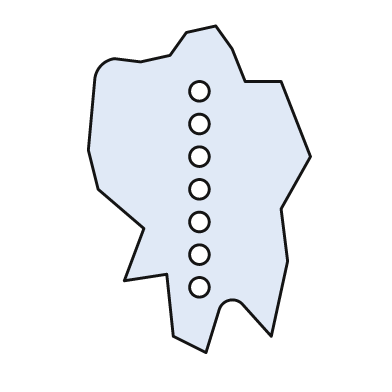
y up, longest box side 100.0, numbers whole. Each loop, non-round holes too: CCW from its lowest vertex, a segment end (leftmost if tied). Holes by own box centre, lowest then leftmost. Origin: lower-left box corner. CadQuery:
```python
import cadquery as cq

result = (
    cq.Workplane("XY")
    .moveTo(36.0, 0.0)
    .lineTo(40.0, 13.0)
    .threePointArc((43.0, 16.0), (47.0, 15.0))
    .lineTo(56.0, 5.0)
    .lineTo(61.0, 28.0)
    .lineTo(59.0, 44.0)
    .lineTo(68.0, 60.0)
    .lineTo(59.0, 83.0)
    .lineTo(48.0, 83.0)
    .lineTo(44.0, 93.0)
    .lineTo(39.0, 100.0)
    .lineTo(30.0, 98.0)
    .lineTo(25.0, 91.0)
    .lineTo(16.0, 89.0)
    .lineTo(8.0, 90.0)
    .threePointArc((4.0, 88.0), (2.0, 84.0))
    .lineTo(0.0, 62.0)
    .lineTo(3.0, 50.0)
    .lineTo(17.0, 38.0)
    .lineTo(11.0, 22.0)
    .lineTo(24.0, 24.0)
    .lineTo(26.0, 5.0)
    .close()
    .moveTo(34.0, 20.0)
    .circle(3.0)
    .moveTo(34.0, 30.0)
    .circle(3.0)
    .moveTo(34.0, 40.0)
    .circle(3.0)
    .moveTo(34.0, 50.0)
    .circle(3.0)
    .moveTo(34.0, 60.0)
    .circle(3.0)
    .moveTo(34.0, 70.0)
    .circle(3.0)
    .moveTo(34.0, 80.0)
    .circle(3.0)
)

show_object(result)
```